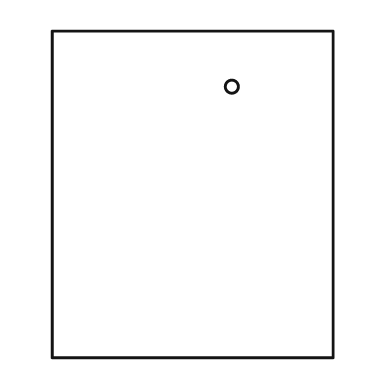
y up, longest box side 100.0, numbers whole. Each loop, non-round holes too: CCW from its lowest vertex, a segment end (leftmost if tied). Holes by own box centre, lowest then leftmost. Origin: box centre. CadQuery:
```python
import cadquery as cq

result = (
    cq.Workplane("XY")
    .moveTo(-43.0, -50.0)
    .lineTo(43.0, -50.0)
    .lineTo(43.0, 50.0)
    .lineTo(-43.0, 50.0)
    .close()
    .moveTo(12.0, 33.0)
    .circle(2.0)
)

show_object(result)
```